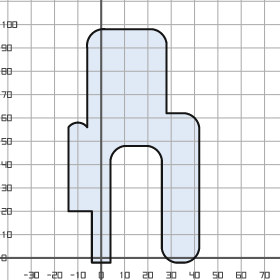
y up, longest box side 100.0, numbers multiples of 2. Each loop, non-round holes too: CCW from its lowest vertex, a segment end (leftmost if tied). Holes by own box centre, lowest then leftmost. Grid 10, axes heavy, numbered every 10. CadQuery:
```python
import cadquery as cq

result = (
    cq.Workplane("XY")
    .moveTo(-4.0, -2.0)
    .lineTo(4.0, -2.0)
    .lineTo(4.0, 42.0)
    .threePointArc((6.0, 46.0), (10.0, 48.0))
    .lineTo(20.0, 48.0)
    .threePointArc((24.0, 46.0), (26.0, 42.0))
    .lineTo(26.0, 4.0)
    .threePointArc((28.0, 0.0), (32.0, -2.0))
    .lineTo(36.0, -2.0)
    .threePointArc((40.0, 0.0), (42.0, 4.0))
    .lineTo(42.0, 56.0)
    .threePointArc((40.0, 60.0), (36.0, 62.0))
    .lineTo(28.0, 62.0)
    .lineTo(28.0, 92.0)
    .threePointArc((26.0, 96.0), (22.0, 98.0))
    .lineTo(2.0, 98.0)
    .threePointArc((-4.0, 96.0), (-6.0, 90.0))
    .lineTo(-6.0, 56.0)
    .threePointArc((-10.0, 58.0), (-14.0, 56.0))
    .lineTo(-14.0, 20.0)
    .lineTo(-4.0, 20.0)
    .close()
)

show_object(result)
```